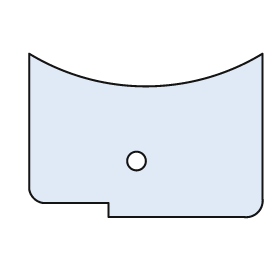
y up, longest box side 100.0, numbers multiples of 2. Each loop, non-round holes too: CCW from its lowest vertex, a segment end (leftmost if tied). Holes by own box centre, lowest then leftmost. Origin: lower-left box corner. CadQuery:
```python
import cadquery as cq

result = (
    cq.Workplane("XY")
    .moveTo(34.0, 0.0)
    .lineTo(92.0, 0.0)
    .threePointArc((98.0, 2.0), (100.0, 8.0))
    .lineTo(100.0, 70.0)
    .threePointArc((50.0, 56.0), (0.0, 70.0))
    .lineTo(0.0, 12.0)
    .threePointArc((2.0, 8.0), (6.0, 6.0))
    .lineTo(34.0, 6.0)
    .close()
    .moveTo(46.0, 24.0)
    .circle(4.0)
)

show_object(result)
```